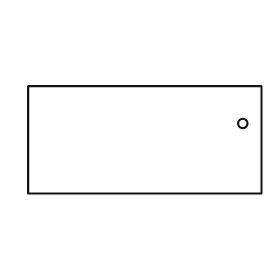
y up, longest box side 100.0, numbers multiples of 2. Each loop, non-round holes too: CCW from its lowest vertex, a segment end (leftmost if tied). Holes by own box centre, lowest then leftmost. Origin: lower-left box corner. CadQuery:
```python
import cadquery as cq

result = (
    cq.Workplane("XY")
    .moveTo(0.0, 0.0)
    .lineTo(100.0, 0.0)
    .lineTo(100.0, 46.0)
    .lineTo(0.0, 46.0)
    .close()
    .moveTo(92.0, 30.0)
    .circle(2.0)
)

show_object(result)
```